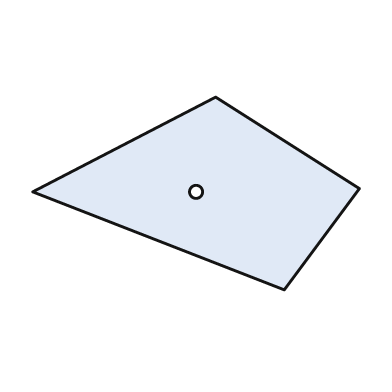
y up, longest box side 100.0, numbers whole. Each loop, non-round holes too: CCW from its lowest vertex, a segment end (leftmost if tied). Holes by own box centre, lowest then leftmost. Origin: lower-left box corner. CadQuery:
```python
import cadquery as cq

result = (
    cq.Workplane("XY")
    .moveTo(77.0, 0.0)
    .lineTo(100.0, 31.0)
    .lineTo(56.0, 59.0)
    .lineTo(0.0, 30.0)
    .close()
    .moveTo(50.0, 30.0)
    .circle(2.0)
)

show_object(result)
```